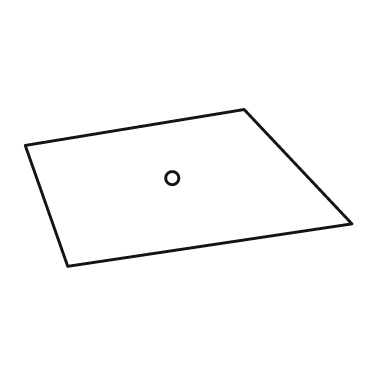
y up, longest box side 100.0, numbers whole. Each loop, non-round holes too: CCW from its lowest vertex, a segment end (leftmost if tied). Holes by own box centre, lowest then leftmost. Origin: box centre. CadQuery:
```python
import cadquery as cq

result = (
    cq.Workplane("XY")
    .moveTo(-37.0, -24.0)
    .lineTo(50.0, -11.0)
    .lineTo(17.0, 24.0)
    .lineTo(-50.0, 13.0)
    .close()
    .moveTo(-5.0, 3.0)
    .circle(2.0)
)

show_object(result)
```